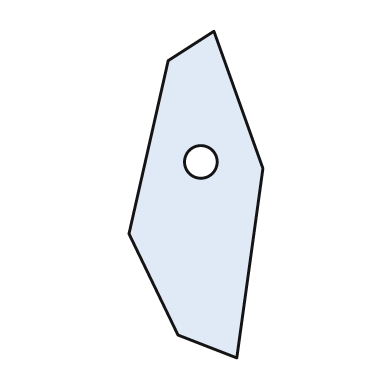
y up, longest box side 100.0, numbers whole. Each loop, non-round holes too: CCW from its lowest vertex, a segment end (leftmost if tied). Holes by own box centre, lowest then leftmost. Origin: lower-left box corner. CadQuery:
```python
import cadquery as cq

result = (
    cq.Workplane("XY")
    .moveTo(33.0, 0.0)
    .lineTo(41.0, 58.0)
    .lineTo(26.0, 100.0)
    .lineTo(12.0, 91.0)
    .lineTo(0.0, 38.0)
    .lineTo(15.0, 7.0)
    .close()
    .moveTo(22.0, 60.0)
    .circle(5.0)
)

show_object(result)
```